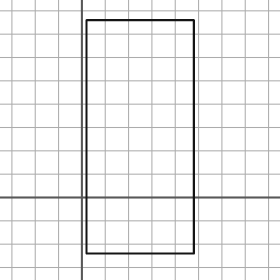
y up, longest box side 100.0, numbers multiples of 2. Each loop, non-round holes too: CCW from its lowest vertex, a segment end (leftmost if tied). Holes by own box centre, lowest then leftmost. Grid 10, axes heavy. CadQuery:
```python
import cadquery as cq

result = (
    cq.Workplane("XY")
    .moveTo(2.0, -24.0)
    .lineTo(48.0, -24.0)
    .lineTo(48.0, 76.0)
    .lineTo(2.0, 76.0)
    .close()
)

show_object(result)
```